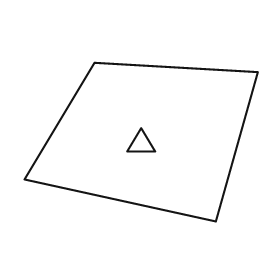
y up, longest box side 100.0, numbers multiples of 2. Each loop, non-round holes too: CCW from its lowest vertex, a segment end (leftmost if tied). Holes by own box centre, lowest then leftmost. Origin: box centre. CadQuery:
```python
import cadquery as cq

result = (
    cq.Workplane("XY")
    .moveTo(32.0, -34.0)
    .lineTo(50.0, 30.0)
    .lineTo(-20.0, 34.0)
    .lineTo(-50.0, -16.0)
    .close()
    .moveTo(-6.0, -4.0)
    .lineTo(6.0, -4.0)
    .lineTo(0.0, 6.0)
    .close()
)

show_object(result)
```